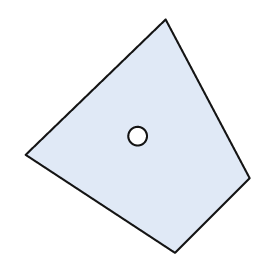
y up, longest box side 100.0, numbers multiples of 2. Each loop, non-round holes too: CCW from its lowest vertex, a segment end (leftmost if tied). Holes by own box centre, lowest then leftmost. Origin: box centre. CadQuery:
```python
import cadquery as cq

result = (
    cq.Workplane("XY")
    .moveTo(16.0, -50.0)
    .lineTo(48.0, -18.0)
    .lineTo(12.0, 50.0)
    .lineTo(-48.0, -8.0)
    .close()
    .moveTo(0.0, 0.0)
    .circle(4.0)
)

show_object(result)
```